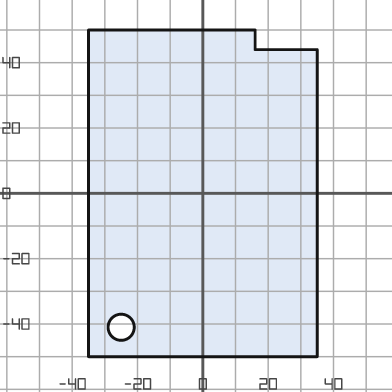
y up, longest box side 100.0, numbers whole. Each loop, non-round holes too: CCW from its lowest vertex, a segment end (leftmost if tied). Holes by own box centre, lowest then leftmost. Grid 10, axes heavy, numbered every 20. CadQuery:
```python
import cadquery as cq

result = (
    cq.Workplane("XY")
    .moveTo(-35.0, -50.0)
    .lineTo(35.0, -50.0)
    .lineTo(35.0, 44.0)
    .lineTo(16.0, 44.0)
    .lineTo(16.0, 50.0)
    .lineTo(-35.0, 50.0)
    .close()
    .moveTo(-25.0, -41.0)
    .circle(4.0)
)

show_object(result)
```